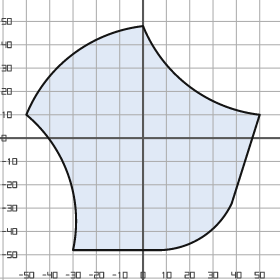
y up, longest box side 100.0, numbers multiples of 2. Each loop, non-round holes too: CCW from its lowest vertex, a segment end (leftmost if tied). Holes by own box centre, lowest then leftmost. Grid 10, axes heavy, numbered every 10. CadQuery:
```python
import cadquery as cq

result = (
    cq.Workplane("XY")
    .moveTo(-30.0, -48.0)
    .lineTo(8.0, -48.0)
    .threePointArc((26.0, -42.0), (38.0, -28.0))
    .lineTo(50.0, 10.0)
    .threePointArc((20.0, 22.0), (0.0, 48.0))
    .threePointArc((-30.0, 36.0), (-50.0, 10.0))
    .threePointArc((-32.0, -16.0), (-30.0, -48.0))
    .close()
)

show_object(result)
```